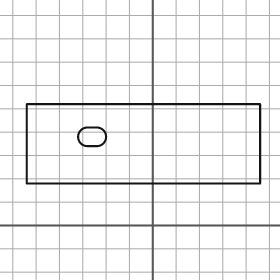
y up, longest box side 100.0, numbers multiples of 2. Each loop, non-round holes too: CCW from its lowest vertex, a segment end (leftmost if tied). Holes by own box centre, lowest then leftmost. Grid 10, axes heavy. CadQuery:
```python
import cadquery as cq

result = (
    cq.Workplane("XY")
    .moveTo(-54.0, 18.0)
    .lineTo(46.0, 18.0)
    .lineTo(46.0, 52.0)
    .lineTo(-54.0, 52.0)
    .close()
    .moveTo(-28.0, 34.0)
    .lineTo(-24.0, 34.0)
    .threePointArc((-20.0, 38.0), (-24.0, 42.0))
    .lineTo(-28.0, 42.0)
    .threePointArc((-32.0, 38.0), (-28.0, 34.0))
    .close()
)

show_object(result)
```